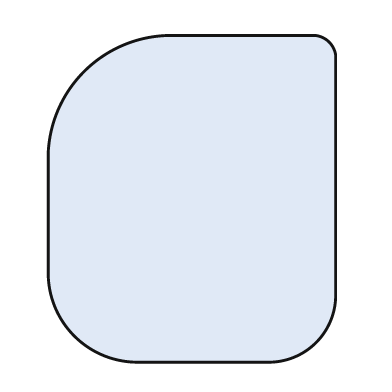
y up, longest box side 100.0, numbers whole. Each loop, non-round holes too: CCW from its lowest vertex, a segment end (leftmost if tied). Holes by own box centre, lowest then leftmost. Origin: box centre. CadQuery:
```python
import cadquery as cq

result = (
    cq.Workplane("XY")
    .moveTo(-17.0, -50.0)
    .lineTo(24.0, -50.0)
    .threePointArc((38.0, -44.0), (44.0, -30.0))
    .lineTo(44.0, 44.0)
    .threePointArc((42.0, 48.0), (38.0, 50.0))
    .lineTo(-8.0, 50.0)
    .threePointArc((-33.0, 39.0), (-44.0, 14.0))
    .lineTo(-44.0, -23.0)
    .threePointArc((-36.0, -42.0), (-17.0, -50.0))
    .close()
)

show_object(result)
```